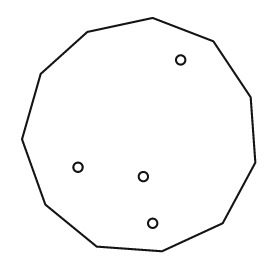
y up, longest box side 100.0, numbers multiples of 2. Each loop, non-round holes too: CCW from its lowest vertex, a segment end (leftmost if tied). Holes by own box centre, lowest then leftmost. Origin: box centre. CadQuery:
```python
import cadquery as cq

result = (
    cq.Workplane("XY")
    .moveTo(10.0, -50.0)
    .lineTo(36.0, -38.0)
    .lineTo(50.0, -12.0)
    .lineTo(48.0, 16.0)
    .lineTo(32.0, 40.0)
    .lineTo(6.0, 50.0)
    .lineTo(-22.0, 44.0)
    .lineTo(-42.0, 26.0)
    .lineTo(-50.0, -2.0)
    .lineTo(-40.0, -30.0)
    .lineTo(-18.0, -48.0)
    .close()
    .moveTo(6.0, -38.0)
    .circle(2.0)
    .moveTo(2.0, -18.0)
    .circle(2.0)
    .moveTo(-26.0, -14.0)
    .circle(2.0)
    .moveTo(18.0, 32.0)
    .circle(2.0)
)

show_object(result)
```